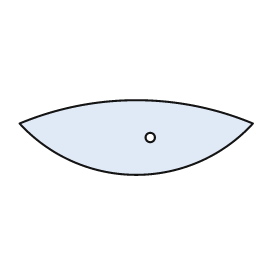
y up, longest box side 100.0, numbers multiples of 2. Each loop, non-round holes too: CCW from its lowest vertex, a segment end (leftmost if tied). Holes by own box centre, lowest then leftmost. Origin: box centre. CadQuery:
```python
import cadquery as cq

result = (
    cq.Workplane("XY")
    .moveTo(-50.0, 6.0)
    .threePointArc((0.0, -16.0), (50.0, 6.0))
    .threePointArc((0.0, 16.0), (-50.0, 6.0))
    .close()
    .moveTo(6.0, 0.0)
    .circle(2.0)
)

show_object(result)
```